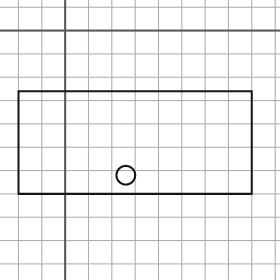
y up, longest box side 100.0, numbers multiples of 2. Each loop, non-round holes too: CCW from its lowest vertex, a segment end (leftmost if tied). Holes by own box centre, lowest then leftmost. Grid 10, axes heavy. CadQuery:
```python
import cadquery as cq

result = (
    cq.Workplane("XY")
    .moveTo(-20.0, -70.0)
    .lineTo(80.0, -70.0)
    .lineTo(80.0, -26.0)
    .lineTo(-20.0, -26.0)
    .close()
    .moveTo(26.0, -62.0)
    .circle(4.0)
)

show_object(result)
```